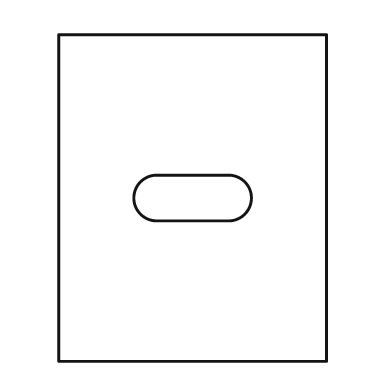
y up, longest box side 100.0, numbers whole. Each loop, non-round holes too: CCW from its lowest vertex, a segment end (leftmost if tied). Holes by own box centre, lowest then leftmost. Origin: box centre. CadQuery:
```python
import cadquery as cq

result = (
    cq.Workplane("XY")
    .moveTo(-41.0, -50.0)
    .lineTo(41.0, -50.0)
    .lineTo(41.0, 50.0)
    .lineTo(-41.0, 50.0)
    .close()
    .moveTo(-11.0, -7.0)
    .lineTo(11.0, -7.0)
    .threePointArc((18.0, 0.0), (11.0, 7.0))
    .lineTo(-11.0, 7.0)
    .threePointArc((-18.0, 0.0), (-11.0, -7.0))
    .close()
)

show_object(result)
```